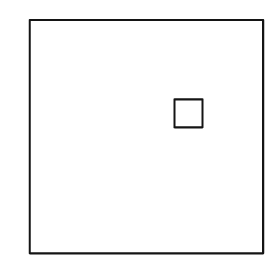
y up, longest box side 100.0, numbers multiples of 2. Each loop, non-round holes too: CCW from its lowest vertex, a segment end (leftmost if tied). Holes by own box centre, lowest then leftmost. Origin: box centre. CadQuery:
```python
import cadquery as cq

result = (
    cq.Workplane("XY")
    .moveTo(-50.0, -50.0)
    .lineTo(50.0, -50.0)
    .lineTo(50.0, 50.0)
    .lineTo(-50.0, 50.0)
    .close()
    .moveTo(12.0, 4.0)
    .lineTo(24.0, 4.0)
    .lineTo(24.0, 16.0)
    .lineTo(12.0, 16.0)
    .close()
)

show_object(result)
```